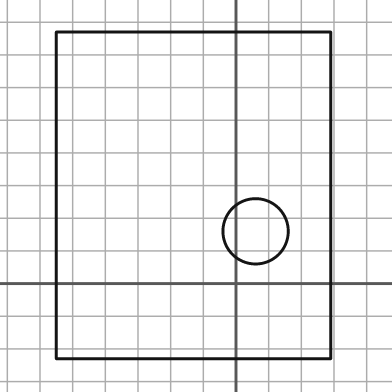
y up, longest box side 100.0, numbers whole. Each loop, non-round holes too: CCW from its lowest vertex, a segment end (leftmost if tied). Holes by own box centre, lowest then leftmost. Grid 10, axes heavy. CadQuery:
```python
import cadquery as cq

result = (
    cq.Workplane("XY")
    .moveTo(-55.0, -23.0)
    .lineTo(29.0, -23.0)
    .lineTo(29.0, 77.0)
    .lineTo(-55.0, 77.0)
    .close()
    .moveTo(6.0, 16.0)
    .circle(10.0)
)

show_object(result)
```